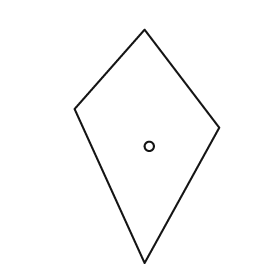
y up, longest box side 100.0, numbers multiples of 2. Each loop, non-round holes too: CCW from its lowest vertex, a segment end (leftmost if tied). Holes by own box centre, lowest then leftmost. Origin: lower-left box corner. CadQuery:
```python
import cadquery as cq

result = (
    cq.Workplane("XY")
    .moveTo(30.0, 0.0)
    .lineTo(62.0, 58.0)
    .lineTo(30.0, 100.0)
    .lineTo(0.0, 66.0)
    .close()
    .moveTo(32.0, 50.0)
    .circle(2.0)
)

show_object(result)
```